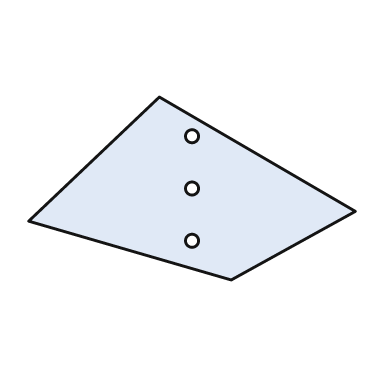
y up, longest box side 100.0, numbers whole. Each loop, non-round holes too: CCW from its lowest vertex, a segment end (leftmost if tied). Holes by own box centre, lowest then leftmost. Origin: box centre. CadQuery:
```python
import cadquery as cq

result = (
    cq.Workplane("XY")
    .moveTo(12.0, -28.0)
    .lineTo(50.0, -7.0)
    .lineTo(-10.0, 28.0)
    .lineTo(-50.0, -10.0)
    .close()
    .moveTo(0.0, -16.0)
    .circle(2.0)
    .moveTo(0.0, 0.0)
    .circle(2.0)
    .moveTo(0.0, 16.0)
    .circle(2.0)
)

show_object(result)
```